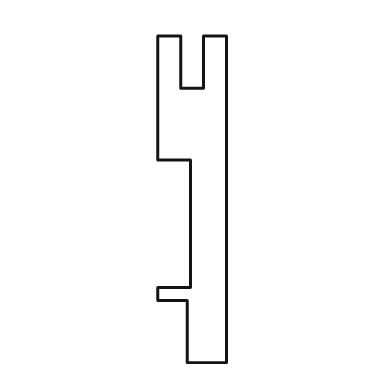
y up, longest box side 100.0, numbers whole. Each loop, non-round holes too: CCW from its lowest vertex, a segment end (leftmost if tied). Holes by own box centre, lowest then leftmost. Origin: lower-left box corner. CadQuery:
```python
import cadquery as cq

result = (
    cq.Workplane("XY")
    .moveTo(9.0, 0.0)
    .lineTo(21.0, 0.0)
    .lineTo(21.0, 100.0)
    .lineTo(14.0, 100.0)
    .lineTo(14.0, 84.0)
    .lineTo(7.0, 84.0)
    .lineTo(7.0, 100.0)
    .lineTo(0.0, 100.0)
    .lineTo(0.0, 62.0)
    .lineTo(10.0, 62.0)
    .lineTo(10.0, 23.0)
    .lineTo(0.0, 23.0)
    .lineTo(0.0, 19.0)
    .lineTo(9.0, 19.0)
    .close()
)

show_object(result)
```